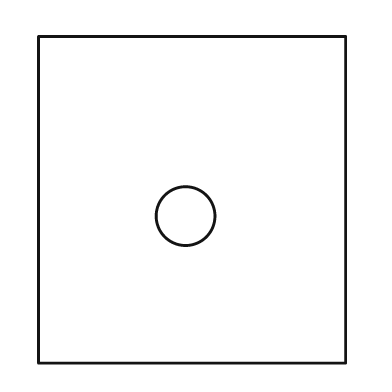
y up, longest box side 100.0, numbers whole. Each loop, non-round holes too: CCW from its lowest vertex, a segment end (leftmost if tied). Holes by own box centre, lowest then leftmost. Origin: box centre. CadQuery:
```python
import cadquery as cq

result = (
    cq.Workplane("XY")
    .moveTo(-47.0, -50.0)
    .lineTo(47.0, -50.0)
    .lineTo(47.0, 50.0)
    .lineTo(-47.0, 50.0)
    .close()
    .moveTo(-2.0, -5.0)
    .circle(9.0)
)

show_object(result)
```